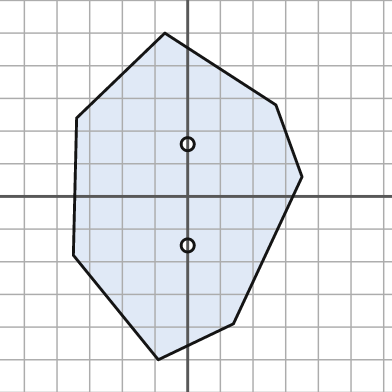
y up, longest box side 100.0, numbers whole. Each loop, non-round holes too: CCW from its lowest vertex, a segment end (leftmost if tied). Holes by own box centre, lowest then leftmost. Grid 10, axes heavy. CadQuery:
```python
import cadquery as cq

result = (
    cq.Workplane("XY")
    .moveTo(-9.0, -50.0)
    .lineTo(14.0, -39.0)
    .lineTo(35.0, 6.0)
    .lineTo(27.0, 28.0)
    .lineTo(-7.0, 50.0)
    .lineTo(-34.0, 24.0)
    .lineTo(-35.0, -18.0)
    .close()
    .moveTo(0.0, -15.0)
    .circle(2.0)
    .moveTo(0.0, 16.0)
    .circle(2.0)
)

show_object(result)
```